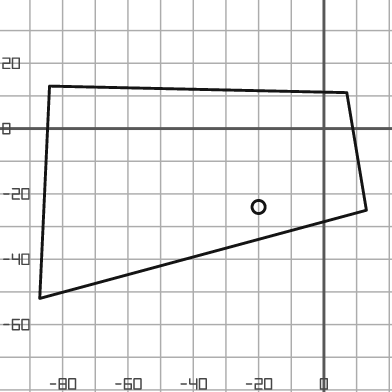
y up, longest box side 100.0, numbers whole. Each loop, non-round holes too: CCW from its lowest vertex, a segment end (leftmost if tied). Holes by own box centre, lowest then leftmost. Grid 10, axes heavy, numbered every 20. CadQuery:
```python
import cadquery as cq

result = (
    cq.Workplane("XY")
    .moveTo(-87.0, -52.0)
    .lineTo(13.0, -25.0)
    .lineTo(7.0, 11.0)
    .lineTo(-84.0, 13.0)
    .close()
    .moveTo(-20.0, -24.0)
    .circle(2.0)
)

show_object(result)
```